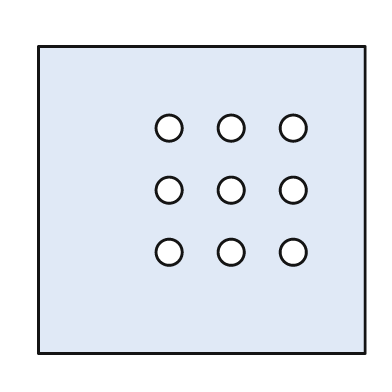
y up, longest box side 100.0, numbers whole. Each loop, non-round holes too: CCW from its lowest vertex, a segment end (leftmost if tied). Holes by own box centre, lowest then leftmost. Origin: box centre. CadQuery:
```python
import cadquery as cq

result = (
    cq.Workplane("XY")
    .moveTo(-50.0, -47.0)
    .lineTo(50.0, -47.0)
    .lineTo(50.0, 47.0)
    .lineTo(-50.0, 47.0)
    .close()
    .moveTo(-10.0, -16.0)
    .circle(4.0)
    .moveTo(9.0, -16.0)
    .circle(4.0)
    .moveTo(28.0, -16.0)
    .circle(4.0)
    .moveTo(-10.0, 3.0)
    .circle(4.0)
    .moveTo(9.0, 3.0)
    .circle(4.0)
    .moveTo(28.0, 3.0)
    .circle(4.0)
    .moveTo(-10.0, 22.0)
    .circle(4.0)
    .moveTo(9.0, 22.0)
    .circle(4.0)
    .moveTo(28.0, 22.0)
    .circle(4.0)
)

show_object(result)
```